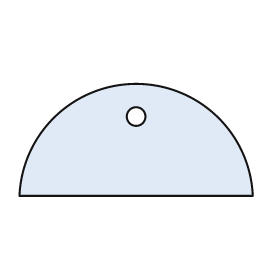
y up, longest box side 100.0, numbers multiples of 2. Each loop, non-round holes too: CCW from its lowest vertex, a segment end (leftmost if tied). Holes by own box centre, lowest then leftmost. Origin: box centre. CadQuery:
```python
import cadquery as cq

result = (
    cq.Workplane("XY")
    .moveTo(-50.0, -24.0)
    .lineTo(50.0, -24.0)
    .threePointArc((0.0, 24.0), (-50.0, -24.0))
    .close()
    .moveTo(0.0, 10.0)
    .circle(4.0)
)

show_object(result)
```